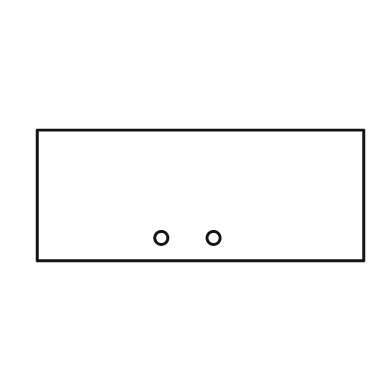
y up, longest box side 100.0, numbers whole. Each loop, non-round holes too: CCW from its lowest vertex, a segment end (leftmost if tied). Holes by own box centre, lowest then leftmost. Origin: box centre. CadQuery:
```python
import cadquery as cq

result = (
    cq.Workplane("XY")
    .moveTo(-50.0, -20.0)
    .lineTo(50.0, -20.0)
    .lineTo(50.0, 20.0)
    .lineTo(-50.0, 20.0)
    .close()
    .moveTo(-12.0, -13.0)
    .circle(2.0)
    .moveTo(4.0, -13.0)
    .circle(2.0)
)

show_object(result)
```